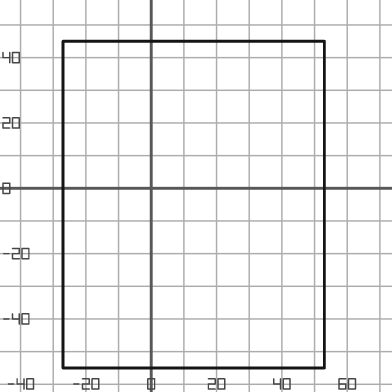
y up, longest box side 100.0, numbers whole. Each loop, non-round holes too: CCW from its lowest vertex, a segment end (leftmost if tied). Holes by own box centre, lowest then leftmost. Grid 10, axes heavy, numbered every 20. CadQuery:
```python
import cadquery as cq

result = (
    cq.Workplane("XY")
    .moveTo(-27.0, -55.0)
    .lineTo(53.0, -55.0)
    .lineTo(53.0, 45.0)
    .lineTo(-27.0, 45.0)
    .close()
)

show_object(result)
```